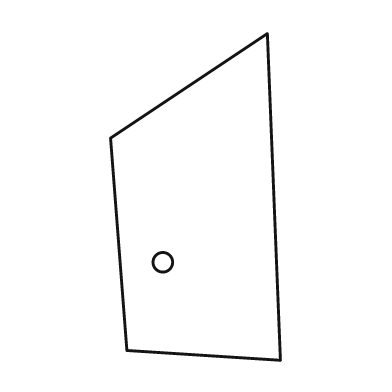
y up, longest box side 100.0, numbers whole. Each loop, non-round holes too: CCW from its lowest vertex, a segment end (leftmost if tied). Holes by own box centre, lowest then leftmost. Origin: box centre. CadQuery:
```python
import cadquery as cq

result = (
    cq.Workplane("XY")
    .moveTo(26.0, -50.0)
    .lineTo(22.0, 50.0)
    .lineTo(-26.0, 18.0)
    .lineTo(-21.0, -47.0)
    .close()
    .moveTo(-10.0, -20.0)
    .circle(3.0)
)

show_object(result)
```